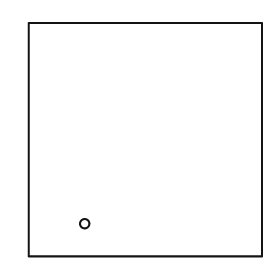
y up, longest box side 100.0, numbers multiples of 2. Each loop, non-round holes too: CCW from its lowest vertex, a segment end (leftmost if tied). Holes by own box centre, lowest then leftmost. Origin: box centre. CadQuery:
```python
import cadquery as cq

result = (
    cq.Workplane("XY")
    .moveTo(-50.0, -50.0)
    .lineTo(50.0, -50.0)
    .lineTo(50.0, 50.0)
    .lineTo(-50.0, 50.0)
    .close()
    .moveTo(-26.0, -36.0)
    .circle(2.0)
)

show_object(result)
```